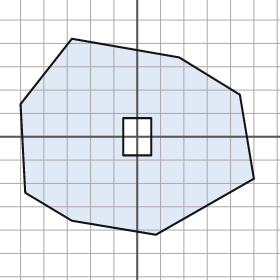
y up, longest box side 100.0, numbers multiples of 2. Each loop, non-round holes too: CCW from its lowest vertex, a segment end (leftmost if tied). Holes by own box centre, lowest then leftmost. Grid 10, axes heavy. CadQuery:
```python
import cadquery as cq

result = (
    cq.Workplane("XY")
    .moveTo(8.0, -42.0)
    .lineTo(50.0, -18.0)
    .lineTo(44.0, 18.0)
    .lineTo(18.0, 34.0)
    .lineTo(-28.0, 42.0)
    .lineTo(-50.0, 14.0)
    .lineTo(-48.0, -24.0)
    .lineTo(-28.0, -36.0)
    .close()
    .moveTo(-6.0, -8.0)
    .lineTo(6.0, -8.0)
    .lineTo(6.0, 8.0)
    .lineTo(-6.0, 8.0)
    .close()
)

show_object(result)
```